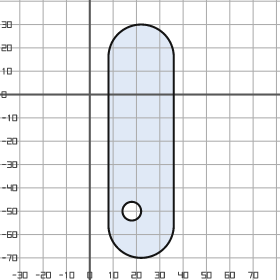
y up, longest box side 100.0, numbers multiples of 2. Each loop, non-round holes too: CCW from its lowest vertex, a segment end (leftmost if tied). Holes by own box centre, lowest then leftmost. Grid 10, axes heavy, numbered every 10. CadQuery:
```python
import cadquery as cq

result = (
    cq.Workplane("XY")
    .moveTo(8.0, -56.0)
    .threePointArc((22.0, -70.0), (36.0, -56.0))
    .lineTo(36.0, 16.0)
    .threePointArc((22.0, 30.0), (8.0, 16.0))
    .close()
    .moveTo(18.0, -50.0)
    .circle(4.0)
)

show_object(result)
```